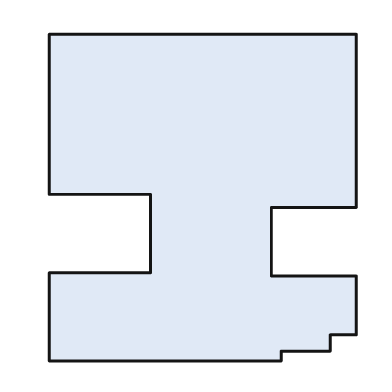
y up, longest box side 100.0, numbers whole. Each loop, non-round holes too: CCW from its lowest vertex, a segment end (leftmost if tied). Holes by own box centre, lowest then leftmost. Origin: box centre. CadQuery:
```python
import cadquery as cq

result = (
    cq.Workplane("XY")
    .moveTo(-47.0, -50.0)
    .lineTo(24.0, -50.0)
    .lineTo(24.0, -47.0)
    .lineTo(39.0, -47.0)
    .lineTo(39.0, -42.0)
    .lineTo(47.0, -42.0)
    .lineTo(47.0, -24.0)
    .lineTo(21.0, -24.0)
    .lineTo(21.0, -3.0)
    .lineTo(47.0, -3.0)
    .lineTo(47.0, 50.0)
    .lineTo(-47.0, 50.0)
    .lineTo(-47.0, 1.0)
    .lineTo(-16.0, 1.0)
    .lineTo(-16.0, -23.0)
    .lineTo(-47.0, -23.0)
    .close()
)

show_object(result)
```